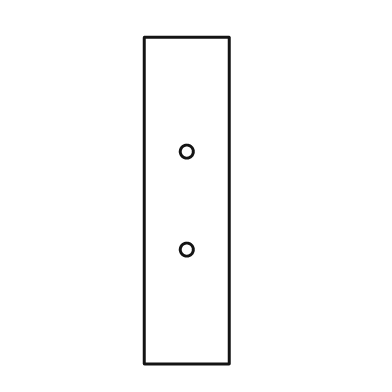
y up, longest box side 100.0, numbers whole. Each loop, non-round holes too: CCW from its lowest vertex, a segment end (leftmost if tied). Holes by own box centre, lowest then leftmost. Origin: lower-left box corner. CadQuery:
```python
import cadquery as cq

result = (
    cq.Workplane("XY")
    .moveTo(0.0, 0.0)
    .lineTo(26.0, 0.0)
    .lineTo(26.0, 100.0)
    .lineTo(0.0, 100.0)
    .close()
    .moveTo(13.0, 35.0)
    .circle(2.0)
    .moveTo(13.0, 65.0)
    .circle(2.0)
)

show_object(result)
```